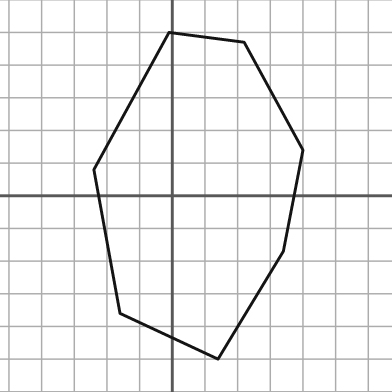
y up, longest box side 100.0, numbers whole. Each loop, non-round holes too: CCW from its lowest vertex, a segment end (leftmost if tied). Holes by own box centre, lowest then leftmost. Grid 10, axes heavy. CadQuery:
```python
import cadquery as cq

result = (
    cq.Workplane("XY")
    .moveTo(14.0, -50.0)
    .lineTo(34.0, -17.0)
    .lineTo(40.0, 14.0)
    .lineTo(22.0, 47.0)
    .lineTo(-1.0, 50.0)
    .lineTo(-24.0, 8.0)
    .lineTo(-16.0, -36.0)
    .close()
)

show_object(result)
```